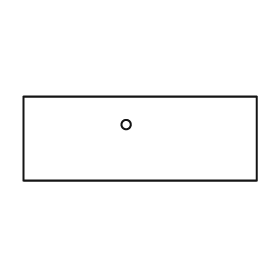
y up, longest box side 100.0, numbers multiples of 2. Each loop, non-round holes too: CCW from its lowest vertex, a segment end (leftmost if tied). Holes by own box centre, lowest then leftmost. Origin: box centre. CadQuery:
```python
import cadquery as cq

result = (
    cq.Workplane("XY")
    .moveTo(-50.0, -18.0)
    .lineTo(50.0, -18.0)
    .lineTo(50.0, 18.0)
    .lineTo(-50.0, 18.0)
    .close()
    .moveTo(-6.0, 6.0)
    .circle(2.0)
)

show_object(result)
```